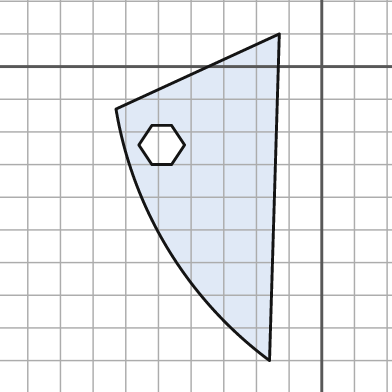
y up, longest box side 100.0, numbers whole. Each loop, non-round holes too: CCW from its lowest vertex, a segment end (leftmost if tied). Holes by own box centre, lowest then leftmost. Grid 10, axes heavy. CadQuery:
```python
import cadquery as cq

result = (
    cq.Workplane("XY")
    .moveTo(-16.0, -90.0)
    .lineTo(-13.0, 10.0)
    .lineTo(-63.0, -13.0)
    .threePointArc((-47.0, -56.0), (-16.0, -90.0))
    .close()
    .moveTo(-52.0, -30.0)
    .lineTo(-46.0, -30.0)
    .lineTo(-42.0, -24.0)
    .lineTo(-46.0, -18.0)
    .lineTo(-52.0, -18.0)
    .lineTo(-56.0, -24.0)
    .close()
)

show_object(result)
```